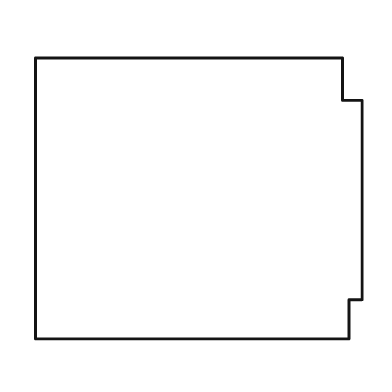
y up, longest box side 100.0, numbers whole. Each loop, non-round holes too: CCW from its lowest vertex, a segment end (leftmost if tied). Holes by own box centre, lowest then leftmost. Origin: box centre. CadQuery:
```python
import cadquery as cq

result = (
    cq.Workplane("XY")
    .moveTo(-50.0, -43.0)
    .lineTo(46.0, -43.0)
    .lineTo(46.0, -31.0)
    .lineTo(50.0, -31.0)
    .lineTo(50.0, 30.0)
    .lineTo(44.0, 30.0)
    .lineTo(44.0, 43.0)
    .lineTo(-50.0, 43.0)
    .close()
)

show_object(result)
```